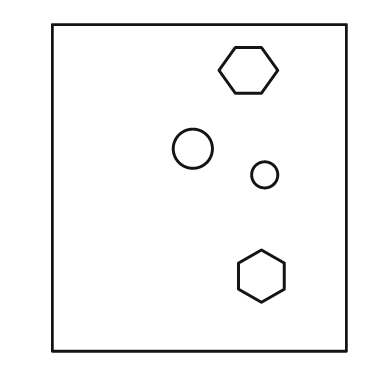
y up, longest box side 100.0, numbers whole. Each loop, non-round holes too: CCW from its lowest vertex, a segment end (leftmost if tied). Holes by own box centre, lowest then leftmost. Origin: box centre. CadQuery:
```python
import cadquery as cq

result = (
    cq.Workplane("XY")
    .moveTo(-45.0, -50.0)
    .lineTo(45.0, -50.0)
    .lineTo(45.0, 50.0)
    .lineTo(-45.0, 50.0)
    .close()
    .moveTo(19.0, -35.0)
    .lineTo(26.0, -31.0)
    .lineTo(26.0, -23.0)
    .lineTo(19.0, -19.0)
    .lineTo(12.0, -23.0)
    .lineTo(12.0, -31.0)
    .close()
    .moveTo(20.0, 4.0)
    .circle(4.0)
    .moveTo(-2.0, 12.0)
    .circle(6.0)
    .moveTo(11.0, 29.0)
    .lineTo(19.0, 29.0)
    .lineTo(24.0, 36.0)
    .lineTo(19.0, 43.0)
    .lineTo(11.0, 43.0)
    .lineTo(6.0, 36.0)
    .close()
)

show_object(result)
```